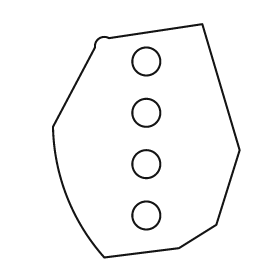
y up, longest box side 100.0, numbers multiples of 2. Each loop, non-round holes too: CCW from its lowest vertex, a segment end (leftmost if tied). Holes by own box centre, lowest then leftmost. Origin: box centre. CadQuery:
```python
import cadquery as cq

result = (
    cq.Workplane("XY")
    .moveTo(-18.0, -50.0)
    .lineTo(14.0, -46.0)
    .lineTo(30.0, -36.0)
    .lineTo(40.0, -4.0)
    .lineTo(24.0, 50.0)
    .lineTo(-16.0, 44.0)
    .threePointArc((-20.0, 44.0), (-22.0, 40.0))
    .lineTo(-40.0, 6.0)
    .threePointArc((-34.0, -24.0), (-18.0, -50.0))
    .close()
    .moveTo(0.0, -32.0)
    .circle(6.0)
    .moveTo(0.0, -10.0)
    .circle(6.0)
    .moveTo(0.0, 12.0)
    .circle(6.0)
    .moveTo(0.0, 34.0)
    .circle(6.0)
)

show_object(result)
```